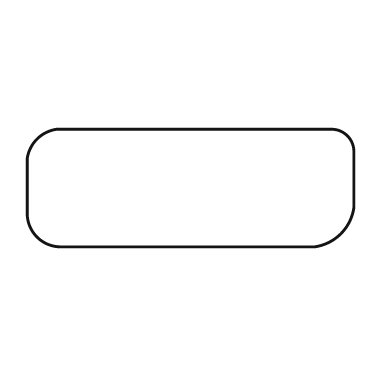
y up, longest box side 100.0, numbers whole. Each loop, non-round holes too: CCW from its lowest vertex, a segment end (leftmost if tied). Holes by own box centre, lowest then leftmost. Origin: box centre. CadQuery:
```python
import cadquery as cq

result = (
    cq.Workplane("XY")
    .moveTo(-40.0, -18.0)
    .lineTo(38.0, -18.0)
    .threePointArc((46.0, -14.0), (50.0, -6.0))
    .lineTo(50.0, 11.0)
    .threePointArc((48.0, 16.0), (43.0, 18.0))
    .lineTo(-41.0, 18.0)
    .threePointArc((-47.0, 15.0), (-50.0, 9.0))
    .lineTo(-50.0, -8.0)
    .threePointArc((-47.0, -15.0), (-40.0, -18.0))
    .close()
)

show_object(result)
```